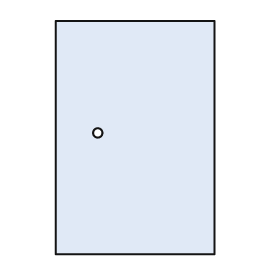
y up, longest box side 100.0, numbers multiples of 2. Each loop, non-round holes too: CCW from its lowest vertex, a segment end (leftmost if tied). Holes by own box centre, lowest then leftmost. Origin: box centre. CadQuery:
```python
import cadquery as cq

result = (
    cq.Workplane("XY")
    .moveTo(-34.0, -50.0)
    .lineTo(34.0, -50.0)
    .lineTo(34.0, 50.0)
    .lineTo(-34.0, 50.0)
    .close()
    .moveTo(-16.0, 2.0)
    .circle(2.0)
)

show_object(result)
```